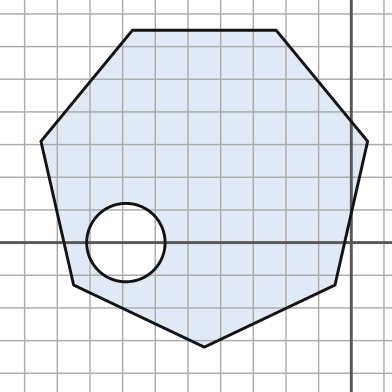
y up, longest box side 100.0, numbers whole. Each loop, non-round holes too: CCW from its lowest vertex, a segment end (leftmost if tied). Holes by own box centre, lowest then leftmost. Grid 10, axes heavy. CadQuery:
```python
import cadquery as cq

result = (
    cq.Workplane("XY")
    .moveTo(-45.0, -32.0)
    .lineTo(-5.0, -13.0)
    .lineTo(5.0, 31.0)
    .lineTo(-23.0, 65.0)
    .lineTo(-67.0, 65.0)
    .lineTo(-95.0, 31.0)
    .lineTo(-85.0, -13.0)
    .close()
    .moveTo(-69.0, 0.0)
    .circle(12.0)
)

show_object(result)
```